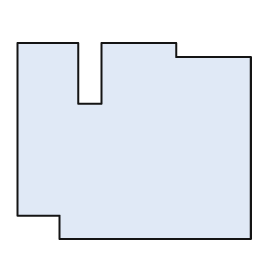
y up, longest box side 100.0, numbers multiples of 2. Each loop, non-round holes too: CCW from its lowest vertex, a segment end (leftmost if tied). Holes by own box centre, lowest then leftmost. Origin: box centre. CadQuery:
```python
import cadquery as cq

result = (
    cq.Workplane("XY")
    .moveTo(-32.0, -42.0)
    .lineTo(50.0, -42.0)
    .lineTo(50.0, 36.0)
    .lineTo(18.0, 36.0)
    .lineTo(18.0, 42.0)
    .lineTo(-14.0, 42.0)
    .lineTo(-14.0, 16.0)
    .lineTo(-24.0, 16.0)
    .lineTo(-24.0, 42.0)
    .lineTo(-50.0, 42.0)
    .lineTo(-50.0, -32.0)
    .lineTo(-32.0, -32.0)
    .close()
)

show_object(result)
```